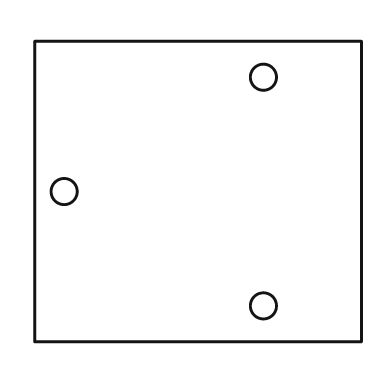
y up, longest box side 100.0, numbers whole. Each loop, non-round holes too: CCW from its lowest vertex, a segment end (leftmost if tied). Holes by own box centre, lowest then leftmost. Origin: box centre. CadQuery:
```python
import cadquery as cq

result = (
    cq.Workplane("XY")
    .moveTo(-50.0, -46.0)
    .lineTo(50.0, -46.0)
    .lineTo(50.0, 46.0)
    .lineTo(-50.0, 46.0)
    .close()
    .moveTo(20.0, -35.0)
    .circle(4.0)
    .moveTo(-41.0, 0.0)
    .circle(4.0)
    .moveTo(20.0, 35.0)
    .circle(4.0)
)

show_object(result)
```